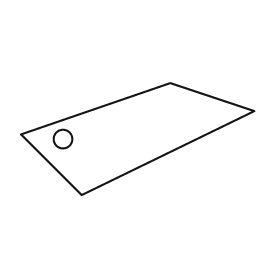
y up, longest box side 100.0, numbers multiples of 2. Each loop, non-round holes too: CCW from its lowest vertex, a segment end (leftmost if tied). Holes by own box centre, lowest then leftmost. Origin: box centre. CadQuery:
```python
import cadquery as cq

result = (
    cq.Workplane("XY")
    .moveTo(-24.0, -24.0)
    .lineTo(50.0, 12.0)
    .lineTo(14.0, 24.0)
    .lineTo(-50.0, 2.0)
    .close()
    .moveTo(-32.0, 0.0)
    .circle(4.0)
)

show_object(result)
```